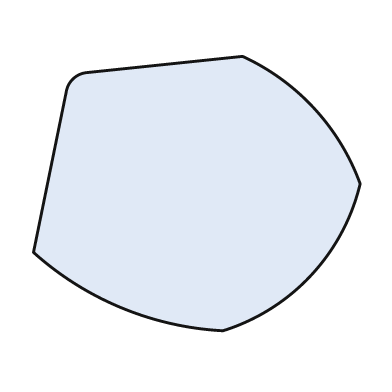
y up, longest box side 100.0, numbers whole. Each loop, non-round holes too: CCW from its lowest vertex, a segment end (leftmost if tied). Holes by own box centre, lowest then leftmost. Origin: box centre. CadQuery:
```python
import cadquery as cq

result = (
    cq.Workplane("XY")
    .moveTo(8.0, -42.0)
    .threePointArc((35.0, -25.0), (50.0, 3.0))
    .threePointArc((36.0, 26.0), (14.0, 42.0))
    .lineTo(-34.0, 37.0)
    .threePointArc((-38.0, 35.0), (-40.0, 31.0))
    .lineTo(-50.0, -18.0)
    .threePointArc((-23.0, -35.0), (8.0, -42.0))
    .close()
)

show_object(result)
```